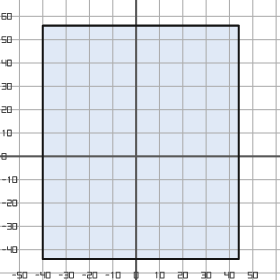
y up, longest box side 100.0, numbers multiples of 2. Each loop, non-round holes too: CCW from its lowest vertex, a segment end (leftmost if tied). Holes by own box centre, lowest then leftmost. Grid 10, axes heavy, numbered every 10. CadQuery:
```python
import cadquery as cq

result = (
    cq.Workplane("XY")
    .moveTo(-40.0, -44.0)
    .lineTo(44.0, -44.0)
    .lineTo(44.0, 56.0)
    .lineTo(-40.0, 56.0)
    .close()
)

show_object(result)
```